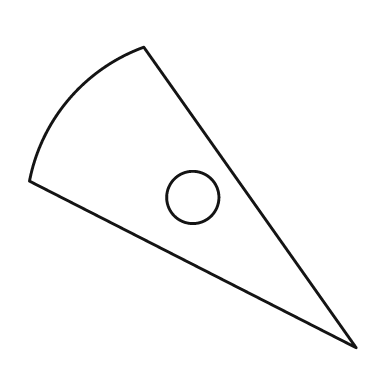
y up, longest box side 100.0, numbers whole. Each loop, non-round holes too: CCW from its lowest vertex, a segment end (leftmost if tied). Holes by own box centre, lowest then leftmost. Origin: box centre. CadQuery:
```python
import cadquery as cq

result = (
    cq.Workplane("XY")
    .moveTo(50.0, -46.0)
    .lineTo(-15.0, 46.0)
    .threePointArc((-38.0, 30.0), (-50.0, 5.0))
    .close()
    .moveTo(0.0, 0.0)
    .circle(8.0)
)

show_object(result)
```